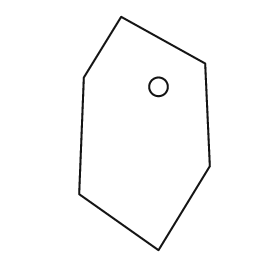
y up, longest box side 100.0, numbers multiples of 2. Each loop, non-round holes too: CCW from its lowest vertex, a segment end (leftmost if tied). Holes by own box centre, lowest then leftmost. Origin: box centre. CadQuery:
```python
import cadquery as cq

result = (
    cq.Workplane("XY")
    .moveTo(6.0, -50.0)
    .lineTo(28.0, -14.0)
    .lineTo(26.0, 30.0)
    .lineTo(-10.0, 50.0)
    .lineTo(-26.0, 24.0)
    .lineTo(-28.0, -26.0)
    .close()
    .moveTo(6.0, 20.0)
    .circle(4.0)
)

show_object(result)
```